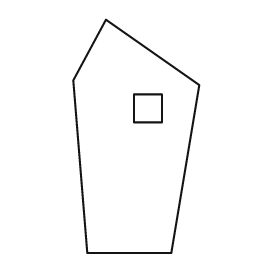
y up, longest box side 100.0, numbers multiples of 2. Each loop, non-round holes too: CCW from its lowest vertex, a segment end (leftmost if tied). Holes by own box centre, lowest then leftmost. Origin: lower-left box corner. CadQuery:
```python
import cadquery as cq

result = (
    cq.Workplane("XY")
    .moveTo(6.0, 0.0)
    .lineTo(42.0, 0.0)
    .lineTo(54.0, 72.0)
    .lineTo(14.0, 100.0)
    .lineTo(0.0, 74.0)
    .close()
    .moveTo(26.0, 56.0)
    .lineTo(38.0, 56.0)
    .lineTo(38.0, 68.0)
    .lineTo(26.0, 68.0)
    .close()
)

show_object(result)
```